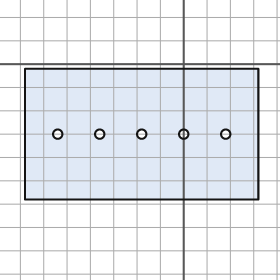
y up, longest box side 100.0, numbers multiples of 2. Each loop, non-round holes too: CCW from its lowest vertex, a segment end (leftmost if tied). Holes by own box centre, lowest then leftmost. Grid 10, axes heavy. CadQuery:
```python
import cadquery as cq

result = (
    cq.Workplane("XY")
    .moveTo(-68.0, -58.0)
    .lineTo(32.0, -58.0)
    .lineTo(32.0, -2.0)
    .lineTo(-68.0, -2.0)
    .close()
    .moveTo(-54.0, -30.0)
    .circle(2.0)
    .moveTo(-36.0, -30.0)
    .circle(2.0)
    .moveTo(-18.0, -30.0)
    .circle(2.0)
    .moveTo(0.0, -30.0)
    .circle(2.0)
    .moveTo(18.0, -30.0)
    .circle(2.0)
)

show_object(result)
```